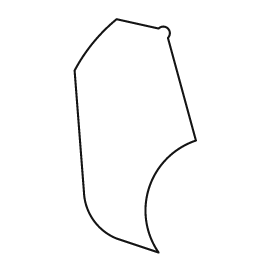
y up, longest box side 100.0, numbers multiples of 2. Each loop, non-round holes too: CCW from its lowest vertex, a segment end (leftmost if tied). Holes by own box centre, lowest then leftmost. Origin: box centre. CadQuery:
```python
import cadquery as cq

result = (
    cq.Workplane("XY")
    .moveTo(10.0, -50.0)
    .threePointArc((6.0, -22.0), (26.0, -2.0))
    .lineTo(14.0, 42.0)
    .threePointArc((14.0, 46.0), (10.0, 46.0))
    .lineTo(-8.0, 50.0)
    .threePointArc((-18.0, 40.0), (-26.0, 28.0))
    .lineTo(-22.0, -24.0)
    .threePointArc((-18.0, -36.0), (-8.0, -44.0))
    .close()
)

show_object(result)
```